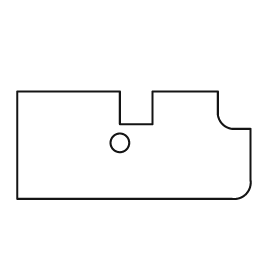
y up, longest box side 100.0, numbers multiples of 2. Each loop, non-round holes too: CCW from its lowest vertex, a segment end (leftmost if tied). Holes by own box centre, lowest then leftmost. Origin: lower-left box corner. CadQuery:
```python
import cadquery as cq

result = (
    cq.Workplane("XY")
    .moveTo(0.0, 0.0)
    .lineTo(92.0, 0.0)
    .threePointArc((98.0, 2.0), (100.0, 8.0))
    .lineTo(100.0, 30.0)
    .lineTo(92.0, 30.0)
    .threePointArc((88.0, 32.0), (86.0, 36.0))
    .lineTo(86.0, 46.0)
    .lineTo(58.0, 46.0)
    .lineTo(58.0, 32.0)
    .lineTo(44.0, 32.0)
    .lineTo(44.0, 46.0)
    .lineTo(0.0, 46.0)
    .close()
    .moveTo(44.0, 24.0)
    .circle(4.0)
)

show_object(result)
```